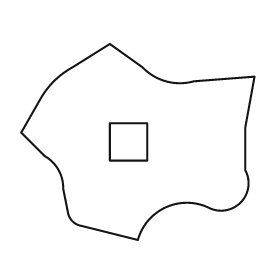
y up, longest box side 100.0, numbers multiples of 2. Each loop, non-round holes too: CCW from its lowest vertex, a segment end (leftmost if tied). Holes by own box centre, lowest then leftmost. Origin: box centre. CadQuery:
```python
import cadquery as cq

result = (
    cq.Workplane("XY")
    .moveTo(0.0, -42.0)
    .threePointArc((12.0, -28.0), (30.0, -28.0))
    .threePointArc((44.0, -26.0), (46.0, -12.0))
    .lineTo(46.0, 6.0)
    .lineTo(50.0, 28.0)
    .lineTo(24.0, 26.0)
    .threePointArc((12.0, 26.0), (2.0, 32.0))
    .lineTo(-12.0, 42.0)
    .lineTo(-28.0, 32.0)
    .threePointArc((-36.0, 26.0), (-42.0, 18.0))
    .lineTo(-50.0, 4.0)
    .lineTo(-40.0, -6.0)
    .threePointArc((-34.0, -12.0), (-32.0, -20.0))
    .lineTo(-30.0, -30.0)
    .threePointArc((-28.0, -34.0), (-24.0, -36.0))
    .close()
    .moveTo(-12.0, -8.0)
    .lineTo(4.0, -8.0)
    .lineTo(4.0, 8.0)
    .lineTo(-12.0, 8.0)
    .close()
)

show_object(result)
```